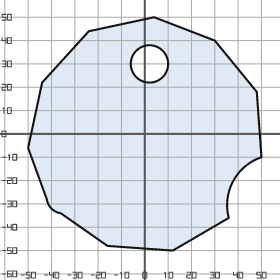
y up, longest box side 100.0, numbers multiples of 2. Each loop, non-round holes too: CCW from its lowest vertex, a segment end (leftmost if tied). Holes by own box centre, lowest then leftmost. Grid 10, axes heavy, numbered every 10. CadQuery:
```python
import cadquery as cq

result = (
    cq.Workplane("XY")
    .moveTo(12.0, -50.0)
    .lineTo(36.0, -36.0)
    .threePointArc((38.0, -20.0), (50.0, -10.0))
    .lineTo(48.0, 18.0)
    .lineTo(30.0, 40.0)
    .lineTo(4.0, 50.0)
    .lineTo(-24.0, 44.0)
    .lineTo(-44.0, 22.0)
    .lineTo(-50.0, -6.0)
    .lineTo(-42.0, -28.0)
    .threePointArc((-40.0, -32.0), (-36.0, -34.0))
    .lineTo(-16.0, -48.0)
    .close()
    .moveTo(2.0, 30.0)
    .circle(8.0)
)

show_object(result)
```